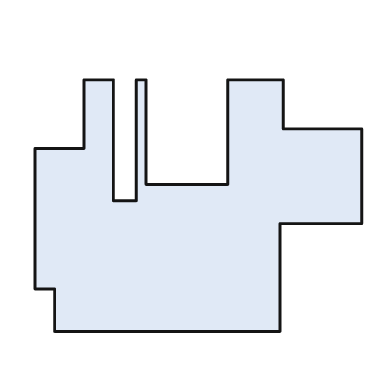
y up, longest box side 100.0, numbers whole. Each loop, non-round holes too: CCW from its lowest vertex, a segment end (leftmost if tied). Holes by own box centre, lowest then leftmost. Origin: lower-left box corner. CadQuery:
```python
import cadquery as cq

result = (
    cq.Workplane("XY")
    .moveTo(6.0, 0.0)
    .lineTo(75.0, 0.0)
    .lineTo(75.0, 33.0)
    .lineTo(100.0, 33.0)
    .lineTo(100.0, 62.0)
    .lineTo(76.0, 62.0)
    .lineTo(76.0, 77.0)
    .lineTo(59.0, 77.0)
    .lineTo(59.0, 45.0)
    .lineTo(34.0, 45.0)
    .lineTo(34.0, 77.0)
    .lineTo(31.0, 77.0)
    .lineTo(31.0, 40.0)
    .lineTo(24.0, 40.0)
    .lineTo(24.0, 77.0)
    .lineTo(15.0, 77.0)
    .lineTo(15.0, 56.0)
    .lineTo(0.0, 56.0)
    .lineTo(0.0, 13.0)
    .lineTo(6.0, 13.0)
    .close()
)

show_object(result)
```